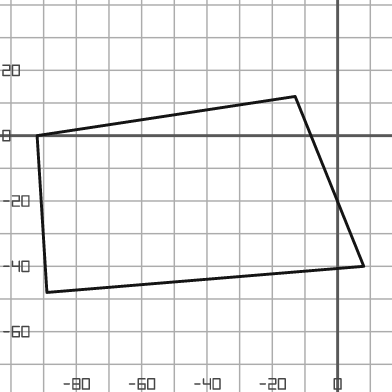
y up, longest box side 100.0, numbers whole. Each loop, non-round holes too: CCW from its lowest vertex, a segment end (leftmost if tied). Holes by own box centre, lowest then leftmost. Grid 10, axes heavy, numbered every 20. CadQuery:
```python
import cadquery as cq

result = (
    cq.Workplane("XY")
    .moveTo(-89.0, -48.0)
    .lineTo(8.0, -40.0)
    .lineTo(-13.0, 12.0)
    .lineTo(-92.0, 0.0)
    .close()
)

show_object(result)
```